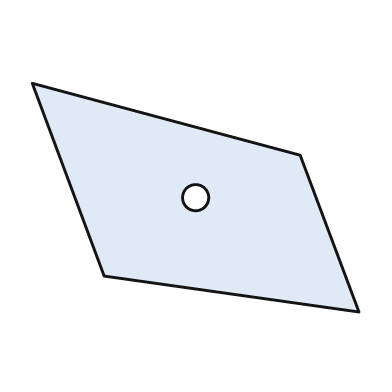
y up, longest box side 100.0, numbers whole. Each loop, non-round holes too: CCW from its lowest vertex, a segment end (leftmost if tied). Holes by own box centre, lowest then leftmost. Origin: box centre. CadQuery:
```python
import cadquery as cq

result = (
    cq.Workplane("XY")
    .moveTo(50.0, -35.0)
    .lineTo(32.0, 13.0)
    .lineTo(-50.0, 35.0)
    .lineTo(-28.0, -24.0)
    .close()
    .moveTo(0.0, 0.0)
    .circle(4.0)
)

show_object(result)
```